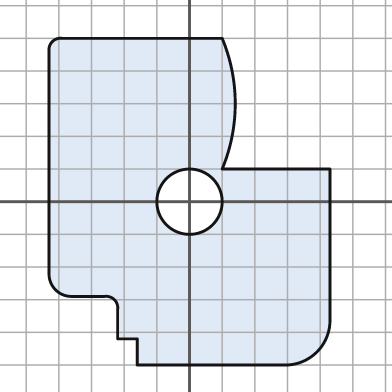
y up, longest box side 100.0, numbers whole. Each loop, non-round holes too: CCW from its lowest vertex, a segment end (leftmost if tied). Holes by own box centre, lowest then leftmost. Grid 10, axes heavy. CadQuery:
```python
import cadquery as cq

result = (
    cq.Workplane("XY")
    .moveTo(-16.0, -50.0)
    .lineTo(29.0, -50.0)
    .threePointArc((39.0, -46.0), (43.0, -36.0))
    .lineTo(43.0, 10.0)
    .lineTo(10.0, 10.0)
    .threePointArc((14.0, 30.0), (10.0, 50.0))
    .lineTo(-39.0, 50.0)
    .threePointArc((-42.0, 49.0), (-43.0, 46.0))
    .lineTo(-43.0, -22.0)
    .threePointArc((-41.0, -27.0), (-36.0, -29.0))
    .lineTo(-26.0, -29.0)
    .threePointArc((-23.0, -30.0), (-22.0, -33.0))
    .lineTo(-22.0, -42.0)
    .lineTo(-16.0, -42.0)
    .close()
    .moveTo(0.0, 0.0)
    .circle(10.0)
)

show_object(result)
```